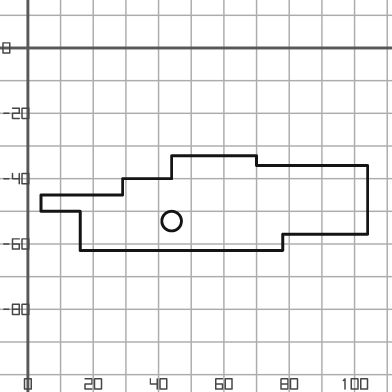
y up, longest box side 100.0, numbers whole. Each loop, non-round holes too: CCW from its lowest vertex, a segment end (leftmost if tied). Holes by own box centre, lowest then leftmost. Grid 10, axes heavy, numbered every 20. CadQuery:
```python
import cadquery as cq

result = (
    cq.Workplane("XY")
    .moveTo(16.0, -62.0)
    .lineTo(78.0, -62.0)
    .lineTo(78.0, -57.0)
    .lineTo(104.0, -57.0)
    .lineTo(104.0, -36.0)
    .lineTo(70.0, -36.0)
    .lineTo(70.0, -33.0)
    .lineTo(44.0, -33.0)
    .lineTo(44.0, -40.0)
    .lineTo(29.0, -40.0)
    .lineTo(29.0, -45.0)
    .lineTo(4.0, -45.0)
    .lineTo(4.0, -50.0)
    .lineTo(16.0, -50.0)
    .close()
    .moveTo(44.0, -53.0)
    .circle(3.0)
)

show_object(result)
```